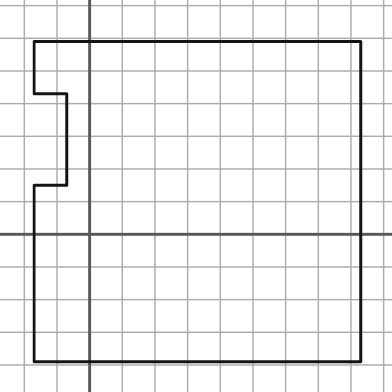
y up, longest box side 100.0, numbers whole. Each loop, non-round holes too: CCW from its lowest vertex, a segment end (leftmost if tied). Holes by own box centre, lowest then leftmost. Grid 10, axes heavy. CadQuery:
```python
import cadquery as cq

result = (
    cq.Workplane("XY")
    .moveTo(-17.0, -39.0)
    .lineTo(83.0, -39.0)
    .lineTo(83.0, 59.0)
    .lineTo(-17.0, 59.0)
    .lineTo(-17.0, 43.0)
    .lineTo(-7.0, 43.0)
    .lineTo(-7.0, 15.0)
    .lineTo(-17.0, 15.0)
    .close()
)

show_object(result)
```